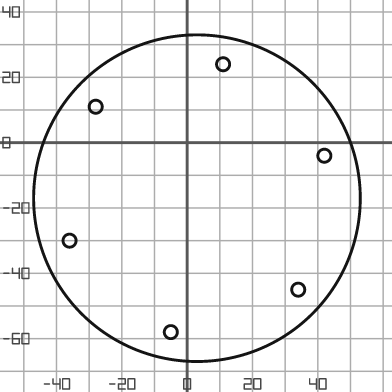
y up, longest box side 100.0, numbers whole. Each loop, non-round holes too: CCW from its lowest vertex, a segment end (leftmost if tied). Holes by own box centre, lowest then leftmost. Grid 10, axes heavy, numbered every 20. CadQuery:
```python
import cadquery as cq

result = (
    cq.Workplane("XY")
    .moveTo(3.0, -17.0)
    .circle(50.0)
    .moveTo(-5.0, -58.0)
    .circle(2.0)
    .moveTo(34.0, -45.0)
    .circle(2.0)
    .moveTo(-36.0, -30.0)
    .circle(2.0)
    .moveTo(42.0, -4.0)
    .circle(2.0)
    .moveTo(-28.0, 11.0)
    .circle(2.0)
    .moveTo(11.0, 24.0)
    .circle(2.0)
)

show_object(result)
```